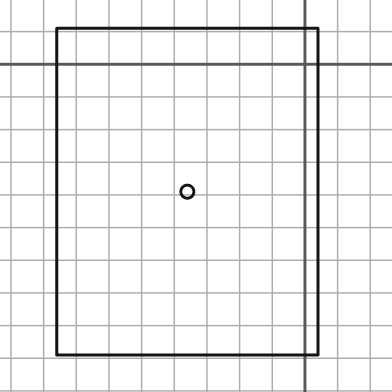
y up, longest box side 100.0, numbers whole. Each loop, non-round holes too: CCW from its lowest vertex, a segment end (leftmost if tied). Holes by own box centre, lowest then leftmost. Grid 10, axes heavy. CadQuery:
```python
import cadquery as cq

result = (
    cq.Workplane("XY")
    .moveTo(-76.0, -89.0)
    .lineTo(4.0, -89.0)
    .lineTo(4.0, 11.0)
    .lineTo(-76.0, 11.0)
    .close()
    .moveTo(-36.0, -39.0)
    .circle(2.0)
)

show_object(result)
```